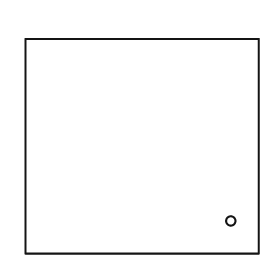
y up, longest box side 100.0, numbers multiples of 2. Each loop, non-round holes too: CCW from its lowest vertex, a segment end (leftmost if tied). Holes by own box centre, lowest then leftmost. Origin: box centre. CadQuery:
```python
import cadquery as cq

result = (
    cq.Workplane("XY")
    .moveTo(-50.0, -46.0)
    .lineTo(50.0, -46.0)
    .lineTo(50.0, 46.0)
    .lineTo(-50.0, 46.0)
    .close()
    .moveTo(38.0, -32.0)
    .circle(2.0)
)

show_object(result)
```